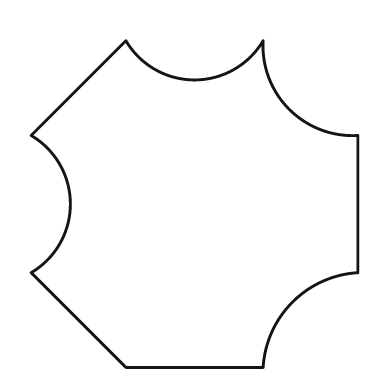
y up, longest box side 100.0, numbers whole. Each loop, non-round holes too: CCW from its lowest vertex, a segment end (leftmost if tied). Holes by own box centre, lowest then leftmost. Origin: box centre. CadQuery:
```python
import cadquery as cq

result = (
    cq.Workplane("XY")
    .moveTo(-21.0, -50.0)
    .lineTo(21.0, -50.0)
    .threePointArc((30.0, -30.0), (50.0, -21.0))
    .lineTo(50.0, 21.0)
    .threePointArc((29.0, 29.0), (21.0, 50.0))
    .threePointArc((0.0, 38.0), (-21.0, 50.0))
    .lineTo(-50.0, 21.0)
    .threePointArc((-38.0, 0.0), (-50.0, -21.0))
    .close()
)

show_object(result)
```